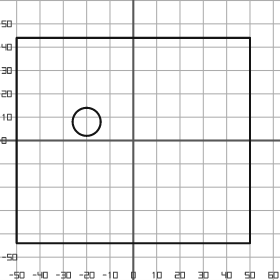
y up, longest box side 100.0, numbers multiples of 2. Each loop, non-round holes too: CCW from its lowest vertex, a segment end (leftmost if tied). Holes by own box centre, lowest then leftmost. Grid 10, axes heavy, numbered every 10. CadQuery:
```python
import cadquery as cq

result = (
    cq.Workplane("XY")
    .moveTo(-50.0, -44.0)
    .lineTo(50.0, -44.0)
    .lineTo(50.0, 44.0)
    .lineTo(-50.0, 44.0)
    .close()
    .moveTo(-20.0, 8.0)
    .circle(6.0)
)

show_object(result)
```